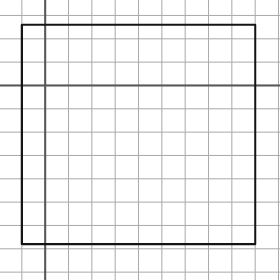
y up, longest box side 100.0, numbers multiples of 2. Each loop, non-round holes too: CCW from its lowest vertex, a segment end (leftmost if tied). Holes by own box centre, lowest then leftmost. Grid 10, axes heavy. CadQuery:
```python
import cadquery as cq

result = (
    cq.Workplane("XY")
    .moveTo(-10.0, -68.0)
    .lineTo(90.0, -68.0)
    .lineTo(90.0, 26.0)
    .lineTo(-10.0, 26.0)
    .close()
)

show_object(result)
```